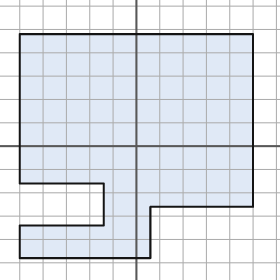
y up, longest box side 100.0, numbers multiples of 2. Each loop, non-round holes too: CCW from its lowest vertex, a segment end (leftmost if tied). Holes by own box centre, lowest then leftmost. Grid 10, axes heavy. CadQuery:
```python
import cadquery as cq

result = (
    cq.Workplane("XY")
    .moveTo(-50.0, -48.0)
    .lineTo(6.0, -48.0)
    .lineTo(6.0, -26.0)
    .lineTo(50.0, -26.0)
    .lineTo(50.0, 48.0)
    .lineTo(-50.0, 48.0)
    .lineTo(-50.0, -16.0)
    .lineTo(-14.0, -16.0)
    .lineTo(-14.0, -34.0)
    .lineTo(-50.0, -34.0)
    .close()
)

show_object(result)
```